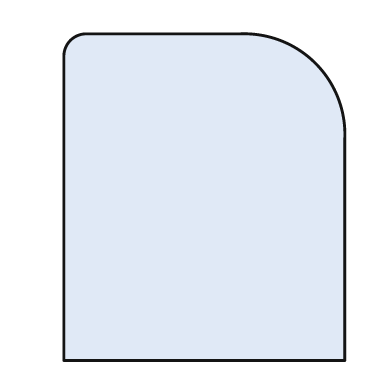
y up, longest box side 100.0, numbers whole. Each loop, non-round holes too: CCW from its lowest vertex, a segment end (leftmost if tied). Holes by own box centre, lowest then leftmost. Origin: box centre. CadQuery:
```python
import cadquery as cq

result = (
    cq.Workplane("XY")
    .moveTo(-43.0, -50.0)
    .lineTo(43.0, -50.0)
    .lineTo(43.0, 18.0)
    .threePointArc((34.0, 41.0), (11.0, 50.0))
    .lineTo(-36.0, 50.0)
    .threePointArc((-41.0, 48.0), (-43.0, 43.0))
    .close()
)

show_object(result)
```